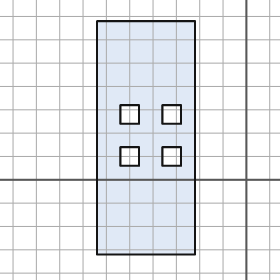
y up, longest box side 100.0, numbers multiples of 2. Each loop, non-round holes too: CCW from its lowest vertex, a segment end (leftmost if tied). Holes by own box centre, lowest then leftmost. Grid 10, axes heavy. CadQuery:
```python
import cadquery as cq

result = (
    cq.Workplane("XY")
    .moveTo(-64.0, -32.0)
    .lineTo(-22.0, -32.0)
    .lineTo(-22.0, 68.0)
    .lineTo(-64.0, 68.0)
    .close()
    .moveTo(-54.0, 6.0)
    .lineTo(-46.0, 6.0)
    .lineTo(-46.0, 14.0)
    .lineTo(-54.0, 14.0)
    .close()
    .moveTo(-36.0, 6.0)
    .lineTo(-28.0, 6.0)
    .lineTo(-28.0, 14.0)
    .lineTo(-36.0, 14.0)
    .close()
    .moveTo(-54.0, 24.0)
    .lineTo(-46.0, 24.0)
    .lineTo(-46.0, 32.0)
    .lineTo(-54.0, 32.0)
    .close()
    .moveTo(-36.0, 24.0)
    .lineTo(-28.0, 24.0)
    .lineTo(-28.0, 32.0)
    .lineTo(-36.0, 32.0)
    .close()
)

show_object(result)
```